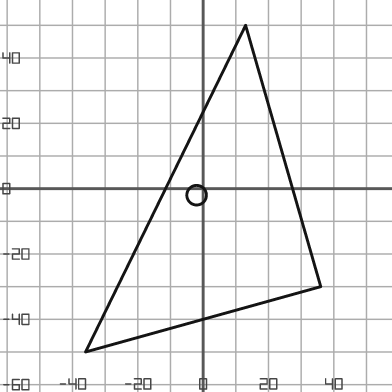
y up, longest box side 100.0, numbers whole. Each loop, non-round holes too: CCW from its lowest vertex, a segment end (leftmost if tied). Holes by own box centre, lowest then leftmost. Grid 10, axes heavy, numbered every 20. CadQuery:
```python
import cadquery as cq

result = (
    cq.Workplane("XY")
    .moveTo(-36.0, -50.0)
    .lineTo(36.0, -30.0)
    .lineTo(13.0, 50.0)
    .close()
    .moveTo(-2.0, -2.0)
    .circle(3.0)
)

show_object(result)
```